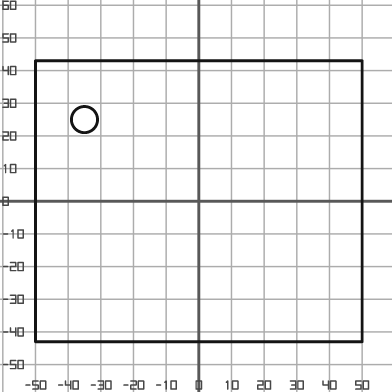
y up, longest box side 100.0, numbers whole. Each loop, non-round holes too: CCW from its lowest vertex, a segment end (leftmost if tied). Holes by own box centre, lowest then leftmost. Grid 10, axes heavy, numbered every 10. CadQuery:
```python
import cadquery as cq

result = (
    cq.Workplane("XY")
    .moveTo(-50.0, -43.0)
    .lineTo(50.0, -43.0)
    .lineTo(50.0, 43.0)
    .lineTo(-50.0, 43.0)
    .close()
    .moveTo(-35.0, 25.0)
    .circle(4.0)
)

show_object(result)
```